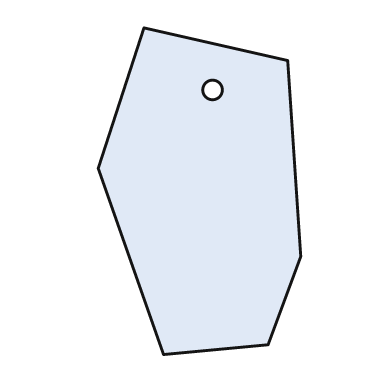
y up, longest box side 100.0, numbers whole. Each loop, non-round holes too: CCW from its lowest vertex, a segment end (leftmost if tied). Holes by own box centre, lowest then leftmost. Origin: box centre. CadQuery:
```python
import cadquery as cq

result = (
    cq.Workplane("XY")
    .moveTo(-11.0, -50.0)
    .lineTo(21.0, -47.0)
    .lineTo(31.0, -20.0)
    .lineTo(27.0, 40.0)
    .lineTo(-17.0, 50.0)
    .lineTo(-31.0, 7.0)
    .close()
    .moveTo(4.0, 31.0)
    .circle(3.0)
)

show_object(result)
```